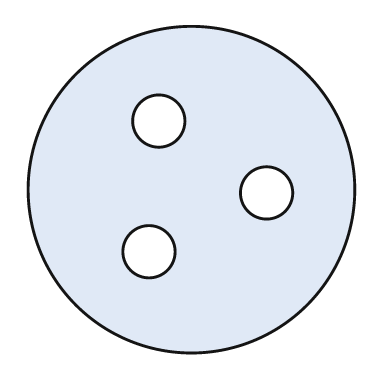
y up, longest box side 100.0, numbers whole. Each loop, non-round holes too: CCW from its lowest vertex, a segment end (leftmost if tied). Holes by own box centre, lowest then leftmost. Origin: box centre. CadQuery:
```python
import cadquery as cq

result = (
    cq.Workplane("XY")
    .moveTo(0.0, 0.0)
    .circle(50.0)
    .moveTo(-13.0, -19.0)
    .circle(8.0)
    .moveTo(23.0, -1.0)
    .circle(8.0)
    .moveTo(-10.0, 21.0)
    .circle(8.0)
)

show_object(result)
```